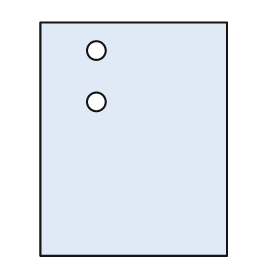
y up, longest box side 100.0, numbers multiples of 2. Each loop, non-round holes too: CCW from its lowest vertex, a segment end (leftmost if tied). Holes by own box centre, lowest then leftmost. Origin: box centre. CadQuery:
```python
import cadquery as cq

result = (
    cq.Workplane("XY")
    .moveTo(-40.0, -50.0)
    .lineTo(40.0, -50.0)
    .lineTo(40.0, 50.0)
    .lineTo(-40.0, 50.0)
    .close()
    .moveTo(-16.0, 16.0)
    .circle(4.0)
    .moveTo(-16.0, 38.0)
    .circle(4.0)
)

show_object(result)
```